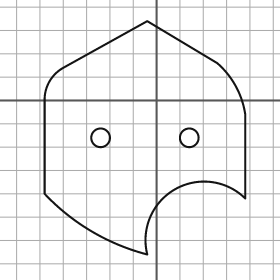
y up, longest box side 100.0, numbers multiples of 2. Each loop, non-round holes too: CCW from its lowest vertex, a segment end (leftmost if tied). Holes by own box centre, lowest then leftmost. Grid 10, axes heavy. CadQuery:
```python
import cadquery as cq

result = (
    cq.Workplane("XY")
    .moveTo(-4.0, -66.0)
    .threePointArc((8.0, -38.0), (38.0, -42.0))
    .lineTo(38.0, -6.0)
    .threePointArc((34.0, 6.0), (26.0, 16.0))
    .lineTo(-4.0, 34.0)
    .lineTo(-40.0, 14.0)
    .threePointArc((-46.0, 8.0), (-48.0, 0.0))
    .lineTo(-48.0, -40.0)
    .threePointArc((-28.0, -56.0), (-4.0, -66.0))
    .close()
    .moveTo(-24.0, -16.0)
    .circle(4.0)
    .moveTo(14.0, -16.0)
    .circle(4.0)
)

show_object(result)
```